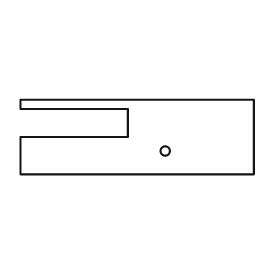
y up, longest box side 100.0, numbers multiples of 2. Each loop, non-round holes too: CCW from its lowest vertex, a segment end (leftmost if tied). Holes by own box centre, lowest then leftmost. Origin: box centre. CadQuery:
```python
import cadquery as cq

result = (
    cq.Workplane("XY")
    .moveTo(-50.0, -16.0)
    .lineTo(50.0, -16.0)
    .lineTo(50.0, 16.0)
    .lineTo(-50.0, 16.0)
    .lineTo(-50.0, 12.0)
    .lineTo(-4.0, 12.0)
    .lineTo(-4.0, 0.0)
    .lineTo(-50.0, 0.0)
    .close()
    .moveTo(12.0, -6.0)
    .circle(2.0)
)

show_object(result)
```